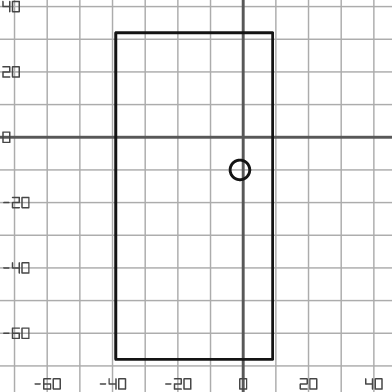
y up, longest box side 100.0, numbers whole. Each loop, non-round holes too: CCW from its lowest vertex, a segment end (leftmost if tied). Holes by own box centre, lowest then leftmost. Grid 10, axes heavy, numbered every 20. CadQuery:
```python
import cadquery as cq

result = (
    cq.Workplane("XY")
    .moveTo(-39.0, -68.0)
    .lineTo(9.0, -68.0)
    .lineTo(9.0, 32.0)
    .lineTo(-39.0, 32.0)
    .close()
    .moveTo(-1.0, -10.0)
    .circle(3.0)
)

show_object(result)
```